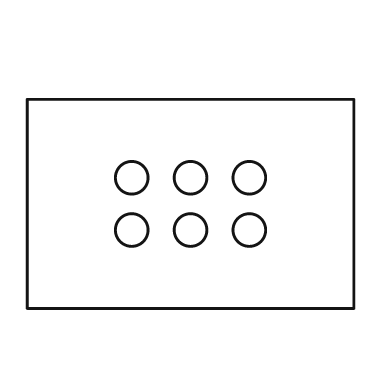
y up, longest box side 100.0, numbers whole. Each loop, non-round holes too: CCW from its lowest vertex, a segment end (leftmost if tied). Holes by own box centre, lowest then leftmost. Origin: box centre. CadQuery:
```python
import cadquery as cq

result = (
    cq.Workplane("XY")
    .moveTo(-50.0, -32.0)
    .lineTo(50.0, -32.0)
    .lineTo(50.0, 32.0)
    .lineTo(-50.0, 32.0)
    .close()
    .moveTo(-18.0, -8.0)
    .circle(5.0)
    .moveTo(0.0, -8.0)
    .circle(5.0)
    .moveTo(18.0, -8.0)
    .circle(5.0)
    .moveTo(-18.0, 8.0)
    .circle(5.0)
    .moveTo(0.0, 8.0)
    .circle(5.0)
    .moveTo(18.0, 8.0)
    .circle(5.0)
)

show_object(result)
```